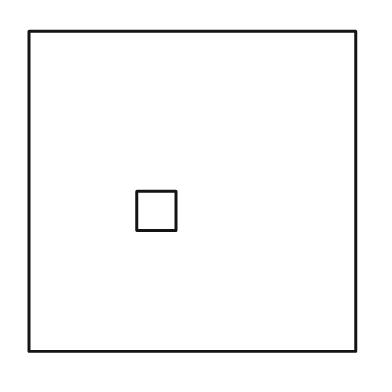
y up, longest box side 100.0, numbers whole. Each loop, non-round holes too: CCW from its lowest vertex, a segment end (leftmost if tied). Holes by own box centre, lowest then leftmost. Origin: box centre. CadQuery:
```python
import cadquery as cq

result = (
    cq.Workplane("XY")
    .moveTo(-50.0, -49.0)
    .lineTo(50.0, -49.0)
    .lineTo(50.0, 49.0)
    .lineTo(-50.0, 49.0)
    .close()
    .moveTo(-17.0, -12.0)
    .lineTo(-5.0, -12.0)
    .lineTo(-5.0, 0.0)
    .lineTo(-17.0, 0.0)
    .close()
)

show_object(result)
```